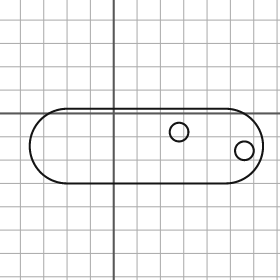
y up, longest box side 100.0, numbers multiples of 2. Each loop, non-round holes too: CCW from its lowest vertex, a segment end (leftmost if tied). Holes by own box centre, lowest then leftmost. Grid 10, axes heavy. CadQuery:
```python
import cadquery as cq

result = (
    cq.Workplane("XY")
    .moveTo(-20.0, -30.0)
    .lineTo(48.0, -30.0)
    .threePointArc((64.0, -14.0), (48.0, 2.0))
    .lineTo(-20.0, 2.0)
    .threePointArc((-36.0, -14.0), (-20.0, -30.0))
    .close()
    .moveTo(56.0, -16.0)
    .circle(4.0)
    .moveTo(28.0, -8.0)
    .circle(4.0)
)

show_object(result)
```